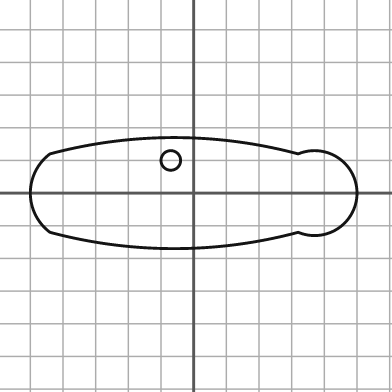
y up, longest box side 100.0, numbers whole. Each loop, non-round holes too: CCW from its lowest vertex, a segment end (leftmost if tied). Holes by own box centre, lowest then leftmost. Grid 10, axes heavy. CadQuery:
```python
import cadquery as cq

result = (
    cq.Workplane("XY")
    .moveTo(-44.0, -12.0)
    .threePointArc((-6.0, -17.0), (32.0, -12.0))
    .threePointArc((50.0, 0.0), (32.0, 12.0))
    .threePointArc((-6.0, 17.0), (-44.0, 12.0))
    .threePointArc((-50.0, 0.0), (-44.0, -12.0))
    .close()
    .moveTo(-7.0, 10.0)
    .circle(3.0)
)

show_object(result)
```